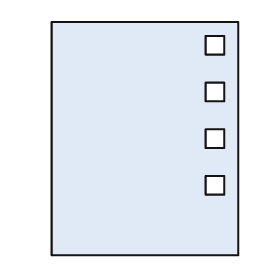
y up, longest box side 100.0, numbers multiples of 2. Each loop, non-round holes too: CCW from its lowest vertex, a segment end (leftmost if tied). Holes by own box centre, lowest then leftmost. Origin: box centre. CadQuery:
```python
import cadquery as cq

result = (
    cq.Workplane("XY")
    .moveTo(-40.0, -50.0)
    .lineTo(40.0, -50.0)
    .lineTo(40.0, 50.0)
    .lineTo(-40.0, 50.0)
    .close()
    .moveTo(26.0, -24.0)
    .lineTo(34.0, -24.0)
    .lineTo(34.0, -16.0)
    .lineTo(26.0, -16.0)
    .close()
    .moveTo(26.0, -4.0)
    .lineTo(34.0, -4.0)
    .lineTo(34.0, 4.0)
    .lineTo(26.0, 4.0)
    .close()
    .moveTo(26.0, 16.0)
    .lineTo(34.0, 16.0)
    .lineTo(34.0, 24.0)
    .lineTo(26.0, 24.0)
    .close()
    .moveTo(26.0, 36.0)
    .lineTo(34.0, 36.0)
    .lineTo(34.0, 44.0)
    .lineTo(26.0, 44.0)
    .close()
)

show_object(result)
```